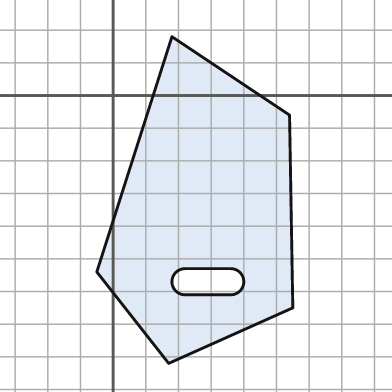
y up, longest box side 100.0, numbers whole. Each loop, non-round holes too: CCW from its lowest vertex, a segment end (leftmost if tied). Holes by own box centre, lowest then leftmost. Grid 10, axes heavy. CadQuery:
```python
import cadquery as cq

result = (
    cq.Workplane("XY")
    .moveTo(17.0, -82.0)
    .lineTo(55.0, -65.0)
    .lineTo(54.0, -6.0)
    .lineTo(18.0, 18.0)
    .lineTo(-5.0, -54.0)
    .close()
    .moveTo(22.0, -61.0)
    .lineTo(36.0, -61.0)
    .threePointArc((40.0, -57.0), (36.0, -53.0))
    .lineTo(22.0, -53.0)
    .threePointArc((18.0, -57.0), (22.0, -61.0))
    .close()
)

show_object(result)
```